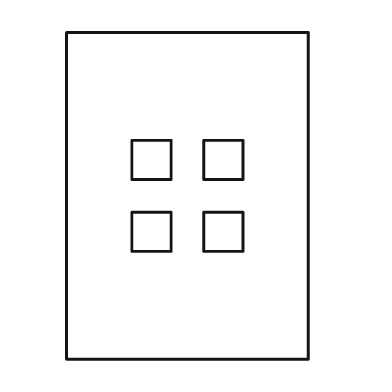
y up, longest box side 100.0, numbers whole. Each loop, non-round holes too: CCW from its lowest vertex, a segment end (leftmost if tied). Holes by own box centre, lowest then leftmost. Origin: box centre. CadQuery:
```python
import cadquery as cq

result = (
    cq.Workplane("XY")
    .moveTo(-37.0, -50.0)
    .lineTo(37.0, -50.0)
    .lineTo(37.0, 50.0)
    .lineTo(-37.0, 50.0)
    .close()
    .moveTo(-17.0, -17.0)
    .lineTo(-5.0, -17.0)
    .lineTo(-5.0, -5.0)
    .lineTo(-17.0, -5.0)
    .close()
    .moveTo(5.0, -17.0)
    .lineTo(17.0, -17.0)
    .lineTo(17.0, -5.0)
    .lineTo(5.0, -5.0)
    .close()
    .moveTo(-17.0, 5.0)
    .lineTo(-5.0, 5.0)
    .lineTo(-5.0, 17.0)
    .lineTo(-17.0, 17.0)
    .close()
    .moveTo(5.0, 5.0)
    .lineTo(17.0, 5.0)
    .lineTo(17.0, 17.0)
    .lineTo(5.0, 17.0)
    .close()
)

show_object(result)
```